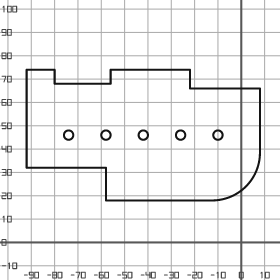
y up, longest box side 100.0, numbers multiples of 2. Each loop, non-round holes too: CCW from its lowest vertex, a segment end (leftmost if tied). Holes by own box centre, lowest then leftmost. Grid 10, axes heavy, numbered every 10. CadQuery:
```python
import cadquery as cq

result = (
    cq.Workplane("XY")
    .moveTo(-58.0, 18.0)
    .lineTo(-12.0, 18.0)
    .threePointArc((2.0, 24.0), (8.0, 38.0))
    .lineTo(8.0, 66.0)
    .lineTo(-22.0, 66.0)
    .lineTo(-22.0, 74.0)
    .lineTo(-56.0, 74.0)
    .lineTo(-56.0, 68.0)
    .lineTo(-80.0, 68.0)
    .lineTo(-80.0, 74.0)
    .lineTo(-92.0, 74.0)
    .lineTo(-92.0, 32.0)
    .lineTo(-58.0, 32.0)
    .close()
    .moveTo(-74.0, 46.0)
    .circle(2.0)
    .moveTo(-58.0, 46.0)
    .circle(2.0)
    .moveTo(-42.0, 46.0)
    .circle(2.0)
    .moveTo(-26.0, 46.0)
    .circle(2.0)
    .moveTo(-10.0, 46.0)
    .circle(2.0)
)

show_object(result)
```